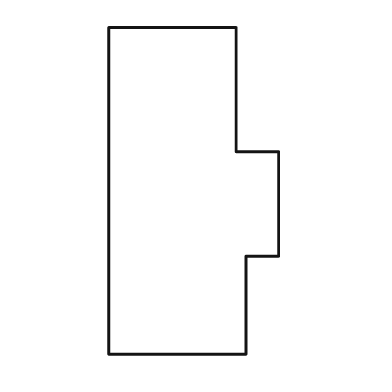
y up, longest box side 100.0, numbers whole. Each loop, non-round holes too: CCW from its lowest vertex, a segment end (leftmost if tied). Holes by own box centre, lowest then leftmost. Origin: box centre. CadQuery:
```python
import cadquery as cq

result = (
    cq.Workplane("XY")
    .moveTo(-26.0, -50.0)
    .lineTo(16.0, -50.0)
    .lineTo(16.0, -20.0)
    .lineTo(26.0, -20.0)
    .lineTo(26.0, 12.0)
    .lineTo(13.0, 12.0)
    .lineTo(13.0, 50.0)
    .lineTo(-26.0, 50.0)
    .close()
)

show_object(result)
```